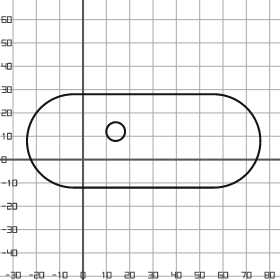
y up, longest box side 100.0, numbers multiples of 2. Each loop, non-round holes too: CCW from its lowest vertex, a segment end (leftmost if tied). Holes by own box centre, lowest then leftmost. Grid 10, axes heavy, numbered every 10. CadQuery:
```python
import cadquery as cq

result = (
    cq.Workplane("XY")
    .moveTo(-4.0, -12.0)
    .lineTo(56.0, -12.0)
    .threePointArc((76.0, 8.0), (56.0, 28.0))
    .lineTo(-4.0, 28.0)
    .threePointArc((-24.0, 8.0), (-4.0, -12.0))
    .close()
    .moveTo(14.0, 12.0)
    .circle(4.0)
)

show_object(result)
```